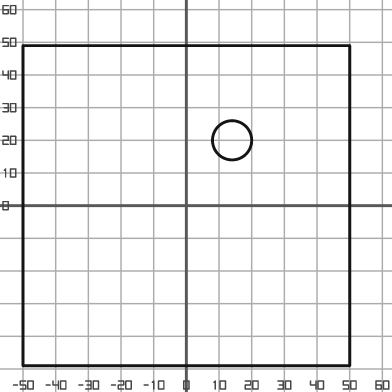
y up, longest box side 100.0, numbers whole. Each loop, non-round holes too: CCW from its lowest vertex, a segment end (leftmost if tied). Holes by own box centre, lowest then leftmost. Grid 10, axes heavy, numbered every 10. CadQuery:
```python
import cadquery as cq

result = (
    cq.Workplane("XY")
    .moveTo(-50.0, -49.0)
    .lineTo(50.0, -49.0)
    .lineTo(50.0, 49.0)
    .lineTo(-50.0, 49.0)
    .close()
    .moveTo(14.0, 20.0)
    .circle(6.0)
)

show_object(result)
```